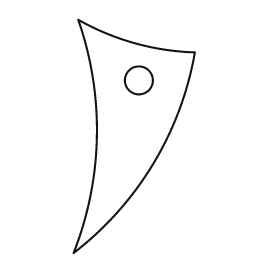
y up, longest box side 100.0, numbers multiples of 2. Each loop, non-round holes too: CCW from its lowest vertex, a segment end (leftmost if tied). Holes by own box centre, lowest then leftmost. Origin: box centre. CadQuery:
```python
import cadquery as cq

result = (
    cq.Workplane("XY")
    .moveTo(-26.0, -50.0)
    .threePointArc((8.0, -12.0), (26.0, 36.0))
    .threePointArc((0.0, 40.0), (-24.0, 50.0))
    .threePointArc((-16.0, 0.0), (-26.0, -50.0))
    .close()
    .moveTo(2.0, 24.0)
    .circle(6.0)
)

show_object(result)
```